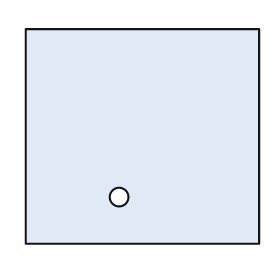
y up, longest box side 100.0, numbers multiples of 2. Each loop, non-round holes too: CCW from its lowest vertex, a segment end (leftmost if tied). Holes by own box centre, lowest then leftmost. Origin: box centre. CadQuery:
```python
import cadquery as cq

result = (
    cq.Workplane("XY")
    .moveTo(-50.0, -46.0)
    .lineTo(50.0, -46.0)
    .lineTo(50.0, 46.0)
    .lineTo(-50.0, 46.0)
    .close()
    .moveTo(-10.0, -26.0)
    .circle(4.0)
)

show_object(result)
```